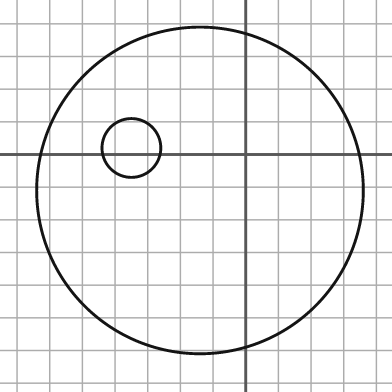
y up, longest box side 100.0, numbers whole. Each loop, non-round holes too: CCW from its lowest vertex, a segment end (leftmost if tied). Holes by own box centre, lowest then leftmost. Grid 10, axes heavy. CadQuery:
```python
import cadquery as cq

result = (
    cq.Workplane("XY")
    .moveTo(-14.0, -11.0)
    .circle(50.0)
    .moveTo(-35.0, 2.0)
    .circle(9.0)
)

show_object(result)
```